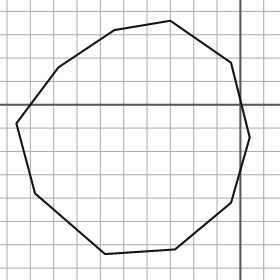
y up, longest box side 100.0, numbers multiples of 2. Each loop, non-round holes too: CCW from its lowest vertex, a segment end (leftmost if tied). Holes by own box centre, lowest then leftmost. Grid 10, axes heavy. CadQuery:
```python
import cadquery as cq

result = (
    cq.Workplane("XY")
    .moveTo(-58.0, -64.0)
    .lineTo(-28.0, -62.0)
    .lineTo(-4.0, -42.0)
    .lineTo(4.0, -14.0)
    .lineTo(-4.0, 18.0)
    .lineTo(-30.0, 36.0)
    .lineTo(-54.0, 32.0)
    .lineTo(-78.0, 16.0)
    .lineTo(-96.0, -8.0)
    .lineTo(-88.0, -38.0)
    .close()
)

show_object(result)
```